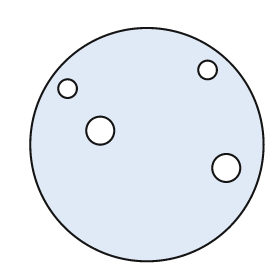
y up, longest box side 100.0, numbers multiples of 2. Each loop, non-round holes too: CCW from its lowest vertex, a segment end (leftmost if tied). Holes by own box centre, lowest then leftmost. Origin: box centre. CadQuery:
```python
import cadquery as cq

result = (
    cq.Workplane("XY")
    .moveTo(0.0, 0.0)
    .circle(50.0)
    .moveTo(34.0, -10.0)
    .circle(6.0)
    .moveTo(-20.0, 6.0)
    .circle(6.0)
    .moveTo(-34.0, 24.0)
    .circle(4.0)
    .moveTo(26.0, 32.0)
    .circle(4.0)
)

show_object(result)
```